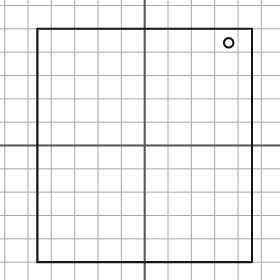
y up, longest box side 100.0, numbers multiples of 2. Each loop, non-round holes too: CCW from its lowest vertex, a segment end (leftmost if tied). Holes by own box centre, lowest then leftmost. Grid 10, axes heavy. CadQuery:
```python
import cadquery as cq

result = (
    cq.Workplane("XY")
    .moveTo(-46.0, -50.0)
    .lineTo(46.0, -50.0)
    .lineTo(46.0, 50.0)
    .lineTo(-46.0, 50.0)
    .close()
    .moveTo(36.0, 44.0)
    .circle(2.0)
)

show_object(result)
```